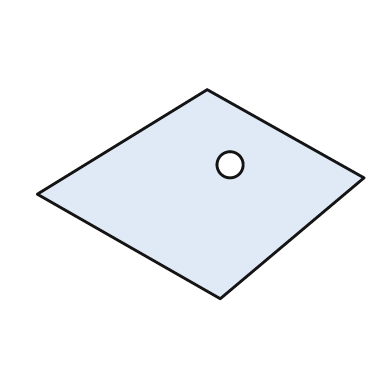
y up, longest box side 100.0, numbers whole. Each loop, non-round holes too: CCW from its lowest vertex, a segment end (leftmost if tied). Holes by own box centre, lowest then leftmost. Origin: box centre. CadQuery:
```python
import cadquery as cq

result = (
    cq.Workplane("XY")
    .moveTo(6.0, -32.0)
    .lineTo(50.0, 5.0)
    .lineTo(2.0, 32.0)
    .lineTo(-50.0, 0.0)
    .close()
    .moveTo(9.0, 9.0)
    .circle(4.0)
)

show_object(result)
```